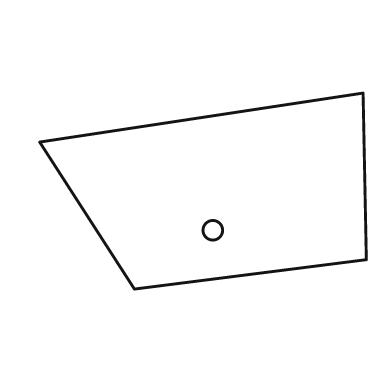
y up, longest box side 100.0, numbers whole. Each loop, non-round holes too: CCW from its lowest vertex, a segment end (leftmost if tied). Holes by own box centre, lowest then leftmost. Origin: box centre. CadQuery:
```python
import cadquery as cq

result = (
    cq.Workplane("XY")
    .moveTo(-21.0, -30.0)
    .lineTo(50.0, -21.0)
    .lineTo(49.0, 30.0)
    .lineTo(-50.0, 15.0)
    .close()
    .moveTo(3.0, -12.0)
    .circle(3.0)
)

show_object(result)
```